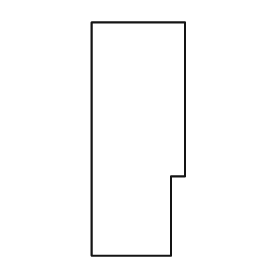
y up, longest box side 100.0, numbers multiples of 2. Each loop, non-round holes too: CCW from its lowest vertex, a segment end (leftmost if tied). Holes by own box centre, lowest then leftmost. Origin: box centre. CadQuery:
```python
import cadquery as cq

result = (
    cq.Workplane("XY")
    .moveTo(-20.0, -50.0)
    .lineTo(14.0, -50.0)
    .lineTo(14.0, -16.0)
    .lineTo(20.0, -16.0)
    .lineTo(20.0, 50.0)
    .lineTo(-20.0, 50.0)
    .close()
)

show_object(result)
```